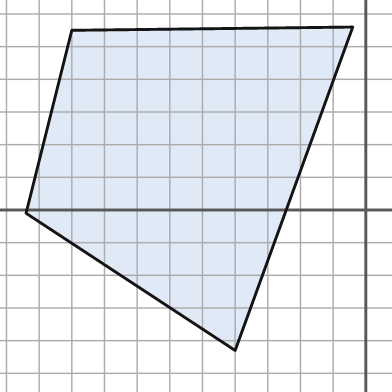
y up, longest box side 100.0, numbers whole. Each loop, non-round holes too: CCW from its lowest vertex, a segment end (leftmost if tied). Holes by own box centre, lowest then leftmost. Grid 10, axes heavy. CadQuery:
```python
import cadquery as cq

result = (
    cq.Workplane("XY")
    .moveTo(-40.0, -43.0)
    .lineTo(-4.0, 56.0)
    .lineTo(-90.0, 55.0)
    .lineTo(-104.0, -1.0)
    .close()
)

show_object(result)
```